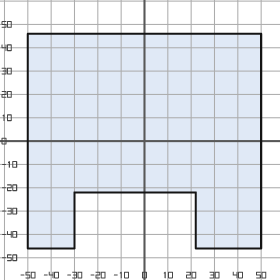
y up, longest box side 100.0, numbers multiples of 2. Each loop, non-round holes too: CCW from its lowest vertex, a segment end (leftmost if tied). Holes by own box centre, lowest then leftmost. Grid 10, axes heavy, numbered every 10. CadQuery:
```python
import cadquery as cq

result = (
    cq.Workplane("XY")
    .moveTo(-50.0, -46.0)
    .lineTo(-30.0, -46.0)
    .lineTo(-30.0, -22.0)
    .lineTo(22.0, -22.0)
    .lineTo(22.0, -46.0)
    .lineTo(50.0, -46.0)
    .lineTo(50.0, 46.0)
    .lineTo(-50.0, 46.0)
    .close()
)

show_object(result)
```